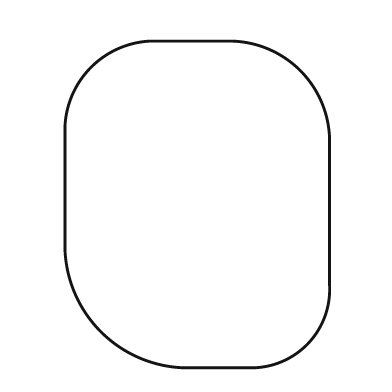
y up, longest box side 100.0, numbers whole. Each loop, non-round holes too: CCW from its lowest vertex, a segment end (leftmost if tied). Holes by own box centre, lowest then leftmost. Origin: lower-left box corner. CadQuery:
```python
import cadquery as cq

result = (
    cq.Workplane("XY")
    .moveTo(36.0, 0.0)
    .lineTo(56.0, 0.0)
    .threePointArc((74.0, 7.0), (81.0, 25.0))
    .lineTo(81.0, 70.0)
    .threePointArc((72.0, 91.0), (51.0, 100.0))
    .lineTo(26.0, 100.0)
    .threePointArc((8.0, 92.0), (0.0, 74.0))
    .lineTo(0.0, 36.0)
    .threePointArc((11.0, 11.0), (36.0, 0.0))
    .close()
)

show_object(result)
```